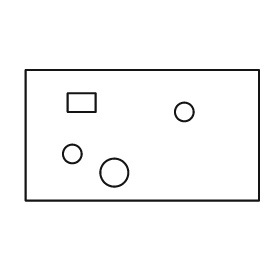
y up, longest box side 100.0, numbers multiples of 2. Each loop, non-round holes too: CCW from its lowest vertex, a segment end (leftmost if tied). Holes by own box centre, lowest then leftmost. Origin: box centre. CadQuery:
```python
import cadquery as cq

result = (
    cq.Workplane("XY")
    .moveTo(-50.0, -28.0)
    .lineTo(50.0, -28.0)
    .lineTo(50.0, 28.0)
    .lineTo(-50.0, 28.0)
    .close()
    .moveTo(-12.0, -16.0)
    .circle(6.0)
    .moveTo(-30.0, -8.0)
    .circle(4.0)
    .moveTo(18.0, 10.0)
    .circle(4.0)
    .moveTo(-32.0, 10.0)
    .lineTo(-20.0, 10.0)
    .lineTo(-20.0, 18.0)
    .lineTo(-32.0, 18.0)
    .close()
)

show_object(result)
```